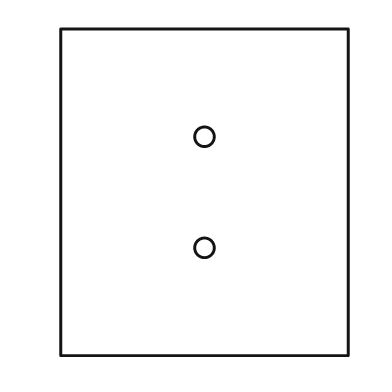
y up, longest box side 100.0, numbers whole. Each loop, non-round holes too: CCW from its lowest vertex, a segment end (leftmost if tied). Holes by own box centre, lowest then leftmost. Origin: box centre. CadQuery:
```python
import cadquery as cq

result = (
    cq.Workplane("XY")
    .moveTo(-44.0, -50.0)
    .lineTo(44.0, -50.0)
    .lineTo(44.0, 50.0)
    .lineTo(-44.0, 50.0)
    .close()
    .moveTo(0.0, -17.0)
    .circle(3.0)
    .moveTo(0.0, 17.0)
    .circle(3.0)
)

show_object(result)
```